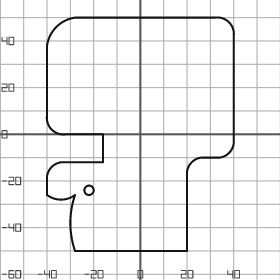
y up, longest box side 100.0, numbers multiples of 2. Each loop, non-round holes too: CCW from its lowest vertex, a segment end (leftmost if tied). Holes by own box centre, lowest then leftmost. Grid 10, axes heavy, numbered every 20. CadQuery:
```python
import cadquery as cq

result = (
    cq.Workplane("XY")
    .moveTo(-28.0, -50.0)
    .lineTo(20.0, -50.0)
    .lineTo(20.0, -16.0)
    .threePointArc((22.0, -12.0), (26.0, -10.0))
    .lineTo(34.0, -10.0)
    .threePointArc((38.0, -8.0), (40.0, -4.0))
    .lineTo(40.0, 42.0)
    .threePointArc((38.0, 48.0), (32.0, 50.0))
    .lineTo(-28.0, 50.0)
    .threePointArc((-36.0, 46.0), (-40.0, 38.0))
    .lineTo(-40.0, 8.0)
    .threePointArc((-38.0, 2.0), (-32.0, 0.0))
    .lineTo(-16.0, 0.0)
    .lineTo(-16.0, -12.0)
    .lineTo(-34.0, -12.0)
    .threePointArc((-38.0, -14.0), (-40.0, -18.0))
    .lineTo(-40.0, -26.0)
    .threePointArc((-34.0, -28.0), (-28.0, -26.0))
    .threePointArc((-30.0, -38.0), (-28.0, -50.0))
    .close()
    .moveTo(-22.0, -24.0)
    .circle(2.0)
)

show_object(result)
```